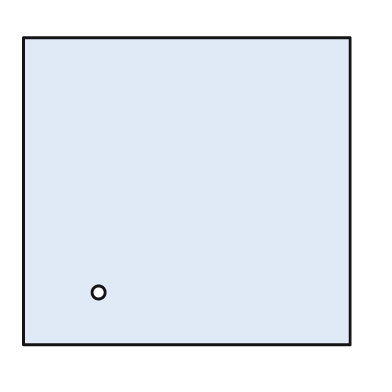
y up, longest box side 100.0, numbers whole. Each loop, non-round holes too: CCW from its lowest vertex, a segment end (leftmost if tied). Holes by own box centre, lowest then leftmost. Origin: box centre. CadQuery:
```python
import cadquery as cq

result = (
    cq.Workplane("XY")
    .moveTo(-50.0, -47.0)
    .lineTo(50.0, -47.0)
    .lineTo(50.0, 47.0)
    .lineTo(-50.0, 47.0)
    .close()
    .moveTo(-27.0, -31.0)
    .circle(2.0)
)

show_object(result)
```